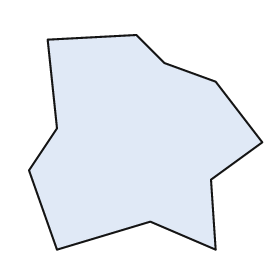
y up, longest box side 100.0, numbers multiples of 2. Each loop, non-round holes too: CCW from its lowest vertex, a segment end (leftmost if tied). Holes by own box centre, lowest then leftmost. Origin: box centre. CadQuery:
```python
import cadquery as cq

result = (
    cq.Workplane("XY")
    .moveTo(-38.0, -46.0)
    .lineTo(2.0, -34.0)
    .lineTo(30.0, -46.0)
    .lineTo(28.0, -16.0)
    .lineTo(50.0, 0.0)
    .lineTo(30.0, 26.0)
    .lineTo(8.0, 34.0)
    .lineTo(-4.0, 46.0)
    .lineTo(-42.0, 44.0)
    .lineTo(-38.0, 6.0)
    .lineTo(-50.0, -12.0)
    .close()
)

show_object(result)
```